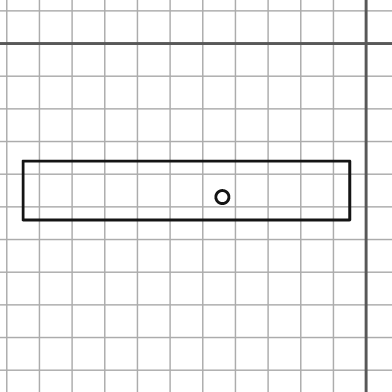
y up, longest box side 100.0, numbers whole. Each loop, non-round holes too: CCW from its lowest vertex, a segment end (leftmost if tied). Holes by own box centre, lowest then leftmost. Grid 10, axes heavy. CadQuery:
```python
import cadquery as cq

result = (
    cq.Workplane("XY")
    .moveTo(-105.0, -54.0)
    .lineTo(-5.0, -54.0)
    .lineTo(-5.0, -36.0)
    .lineTo(-105.0, -36.0)
    .close()
    .moveTo(-44.0, -47.0)
    .circle(2.0)
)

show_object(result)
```